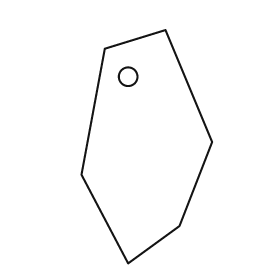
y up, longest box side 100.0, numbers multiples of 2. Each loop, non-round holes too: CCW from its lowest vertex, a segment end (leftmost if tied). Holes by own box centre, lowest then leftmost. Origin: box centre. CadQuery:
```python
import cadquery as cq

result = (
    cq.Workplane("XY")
    .moveTo(-8.0, -50.0)
    .lineTo(14.0, -34.0)
    .lineTo(28.0, 2.0)
    .lineTo(8.0, 50.0)
    .lineTo(-18.0, 42.0)
    .lineTo(-28.0, -12.0)
    .close()
    .moveTo(-8.0, 30.0)
    .circle(4.0)
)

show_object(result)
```